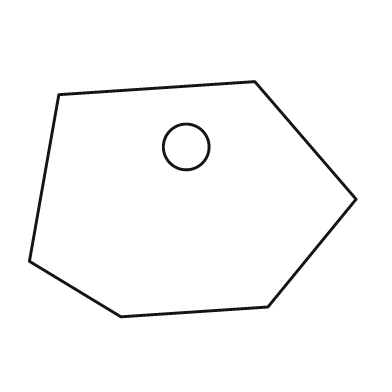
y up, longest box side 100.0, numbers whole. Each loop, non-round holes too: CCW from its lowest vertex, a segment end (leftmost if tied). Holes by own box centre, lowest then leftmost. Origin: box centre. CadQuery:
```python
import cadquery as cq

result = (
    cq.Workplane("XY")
    .moveTo(-22.0, -36.0)
    .lineTo(23.0, -33.0)
    .lineTo(50.0, 0.0)
    .lineTo(19.0, 36.0)
    .lineTo(-41.0, 32.0)
    .lineTo(-50.0, -19.0)
    .close()
    .moveTo(-2.0, 16.0)
    .circle(7.0)
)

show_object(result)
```